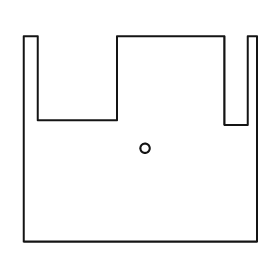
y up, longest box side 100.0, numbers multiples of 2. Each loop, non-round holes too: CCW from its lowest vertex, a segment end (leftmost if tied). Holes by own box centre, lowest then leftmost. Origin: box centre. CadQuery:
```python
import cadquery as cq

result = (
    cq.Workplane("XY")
    .moveTo(-50.0, -44.0)
    .lineTo(50.0, -44.0)
    .lineTo(50.0, 44.0)
    .lineTo(46.0, 44.0)
    .lineTo(46.0, 6.0)
    .lineTo(36.0, 6.0)
    .lineTo(36.0, 44.0)
    .lineTo(-10.0, 44.0)
    .lineTo(-10.0, 8.0)
    .lineTo(-44.0, 8.0)
    .lineTo(-44.0, 44.0)
    .lineTo(-50.0, 44.0)
    .close()
    .moveTo(2.0, -4.0)
    .circle(2.0)
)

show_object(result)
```